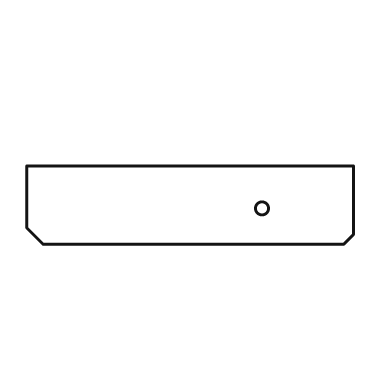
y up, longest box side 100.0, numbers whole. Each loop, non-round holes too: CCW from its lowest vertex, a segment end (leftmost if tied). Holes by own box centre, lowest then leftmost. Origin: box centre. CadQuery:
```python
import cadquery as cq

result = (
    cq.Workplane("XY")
    .moveTo(-45.0, -12.0)
    .lineTo(47.0, -12.0)
    .lineTo(50.0, -9.0)
    .lineTo(50.0, 12.0)
    .lineTo(-50.0, 12.0)
    .lineTo(-50.0, -7.0)
    .close()
    .moveTo(22.0, -1.0)
    .circle(2.0)
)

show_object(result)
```